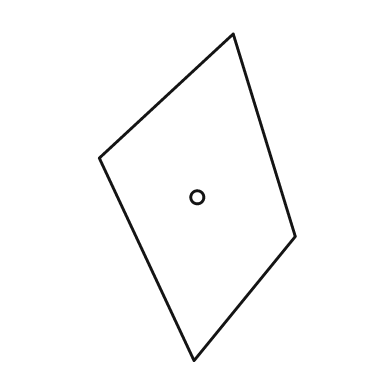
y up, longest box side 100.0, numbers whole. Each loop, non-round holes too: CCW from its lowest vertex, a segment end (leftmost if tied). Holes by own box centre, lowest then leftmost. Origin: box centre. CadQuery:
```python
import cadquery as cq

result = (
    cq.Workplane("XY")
    .moveTo(-1.0, -50.0)
    .lineTo(30.0, -12.0)
    .lineTo(11.0, 50.0)
    .lineTo(-30.0, 12.0)
    .close()
    .moveTo(0.0, 0.0)
    .circle(2.0)
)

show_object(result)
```